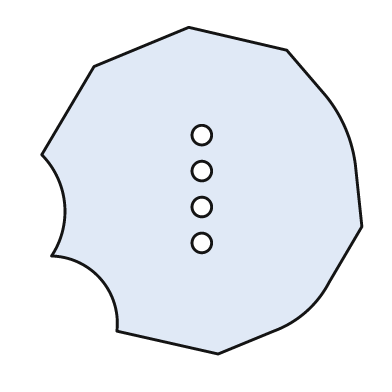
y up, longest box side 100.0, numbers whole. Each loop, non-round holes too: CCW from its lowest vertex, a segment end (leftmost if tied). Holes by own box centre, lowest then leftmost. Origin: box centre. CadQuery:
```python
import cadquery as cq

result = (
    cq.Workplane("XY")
    .moveTo(5.0, -50.0)
    .lineTo(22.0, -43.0)
    .threePointArc((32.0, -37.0), (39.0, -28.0))
    .lineTo(49.0, -11.0)
    .lineTo(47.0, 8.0)
    .threePointArc((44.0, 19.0), (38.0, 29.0))
    .lineTo(26.0, 43.0)
    .lineTo(-4.0, 50.0)
    .lineTo(-33.0, 38.0)
    .lineTo(-49.0, 11.0)
    .threePointArc((-42.0, -4.0), (-46.0, -20.0))
    .threePointArc((-31.0, -27.0), (-26.0, -43.0))
    .close()
    .moveTo(0.0, -16.0)
    .circle(3.0)
    .moveTo(0.0, -5.0)
    .circle(3.0)
    .moveTo(0.0, 6.0)
    .circle(3.0)
    .moveTo(0.0, 17.0)
    .circle(3.0)
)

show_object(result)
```